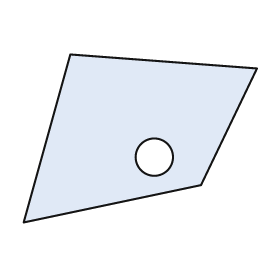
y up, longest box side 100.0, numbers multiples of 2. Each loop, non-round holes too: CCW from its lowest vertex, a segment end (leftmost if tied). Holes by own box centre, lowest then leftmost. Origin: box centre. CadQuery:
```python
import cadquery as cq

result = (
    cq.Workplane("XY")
    .moveTo(-50.0, -36.0)
    .lineTo(26.0, -20.0)
    .lineTo(50.0, 30.0)
    .lineTo(-30.0, 36.0)
    .close()
    .moveTo(6.0, -8.0)
    .circle(8.0)
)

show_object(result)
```